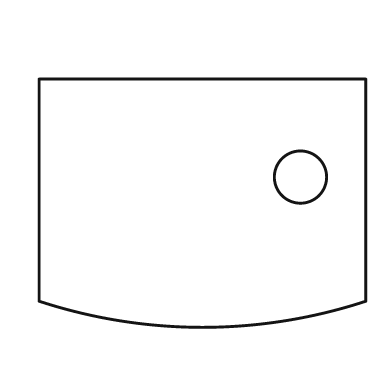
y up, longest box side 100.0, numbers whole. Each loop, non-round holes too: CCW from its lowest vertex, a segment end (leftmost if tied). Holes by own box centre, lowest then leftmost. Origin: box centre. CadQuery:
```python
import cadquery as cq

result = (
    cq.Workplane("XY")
    .moveTo(-50.0, -30.0)
    .threePointArc((0.0, -38.0), (50.0, -30.0))
    .lineTo(50.0, 38.0)
    .lineTo(-50.0, 38.0)
    .close()
    .moveTo(30.0, 8.0)
    .circle(8.0)
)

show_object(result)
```